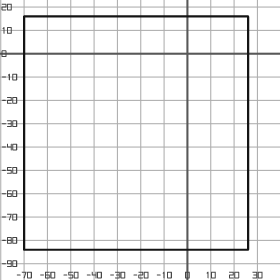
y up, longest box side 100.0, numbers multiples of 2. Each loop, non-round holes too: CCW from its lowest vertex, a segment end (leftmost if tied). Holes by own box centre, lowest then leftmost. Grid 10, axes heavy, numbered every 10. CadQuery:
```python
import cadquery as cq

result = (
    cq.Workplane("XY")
    .moveTo(-70.0, -84.0)
    .lineTo(26.0, -84.0)
    .lineTo(26.0, 16.0)
    .lineTo(-70.0, 16.0)
    .close()
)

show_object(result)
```